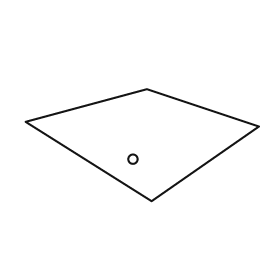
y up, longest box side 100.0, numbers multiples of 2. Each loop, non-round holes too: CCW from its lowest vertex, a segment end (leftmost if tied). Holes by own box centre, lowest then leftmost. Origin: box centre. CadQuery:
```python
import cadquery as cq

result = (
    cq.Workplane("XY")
    .moveTo(4.0, -24.0)
    .lineTo(50.0, 8.0)
    .lineTo(2.0, 24.0)
    .lineTo(-50.0, 10.0)
    .close()
    .moveTo(-4.0, -6.0)
    .circle(2.0)
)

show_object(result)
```